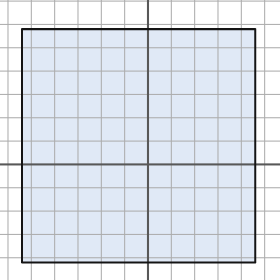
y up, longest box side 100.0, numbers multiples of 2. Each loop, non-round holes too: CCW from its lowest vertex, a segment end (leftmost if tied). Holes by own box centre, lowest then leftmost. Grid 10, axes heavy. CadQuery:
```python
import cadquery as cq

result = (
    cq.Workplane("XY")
    .moveTo(-54.0, -42.0)
    .lineTo(46.0, -42.0)
    .lineTo(46.0, 58.0)
    .lineTo(-54.0, 58.0)
    .close()
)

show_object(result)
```